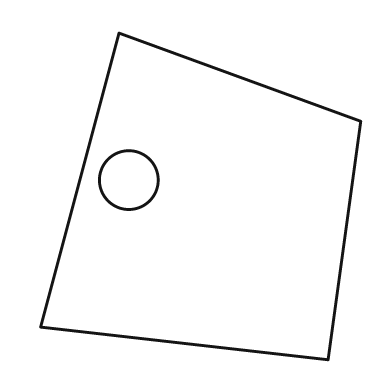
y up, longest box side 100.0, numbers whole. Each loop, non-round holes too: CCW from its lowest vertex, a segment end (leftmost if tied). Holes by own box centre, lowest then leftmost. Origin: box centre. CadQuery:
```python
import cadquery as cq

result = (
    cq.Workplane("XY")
    .moveTo(39.0, -50.0)
    .lineTo(49.0, 23.0)
    .lineTo(-25.0, 50.0)
    .lineTo(-49.0, -40.0)
    .close()
    .moveTo(-22.0, 5.0)
    .circle(9.0)
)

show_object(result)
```